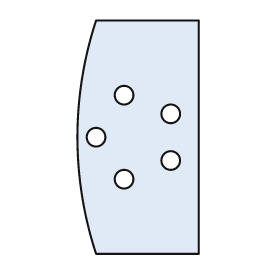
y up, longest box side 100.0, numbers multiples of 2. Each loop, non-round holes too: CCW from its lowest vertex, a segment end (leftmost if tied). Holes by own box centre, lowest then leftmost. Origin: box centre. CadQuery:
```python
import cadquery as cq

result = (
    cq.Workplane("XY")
    .moveTo(-18.0, -50.0)
    .lineTo(26.0, -50.0)
    .lineTo(26.0, 50.0)
    .lineTo(-18.0, 50.0)
    .threePointArc((-26.0, 0.0), (-18.0, -50.0))
    .close()
    .moveTo(-6.0, -18.0)
    .circle(4.0)
    .moveTo(14.0, -10.0)
    .circle(4.0)
    .moveTo(-18.0, 0.0)
    .circle(4.0)
    .moveTo(14.0, 10.0)
    .circle(4.0)
    .moveTo(-6.0, 18.0)
    .circle(4.0)
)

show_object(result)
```